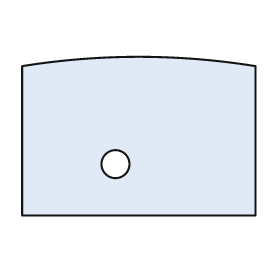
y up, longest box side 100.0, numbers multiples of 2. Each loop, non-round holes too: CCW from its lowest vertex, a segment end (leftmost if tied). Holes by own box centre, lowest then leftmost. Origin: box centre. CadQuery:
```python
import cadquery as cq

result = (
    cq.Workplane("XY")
    .moveTo(-50.0, -34.0)
    .lineTo(50.0, -34.0)
    .lineTo(50.0, 30.0)
    .threePointArc((0.0, 34.0), (-50.0, 30.0))
    .close()
    .moveTo(-10.0, -12.0)
    .circle(6.0)
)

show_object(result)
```